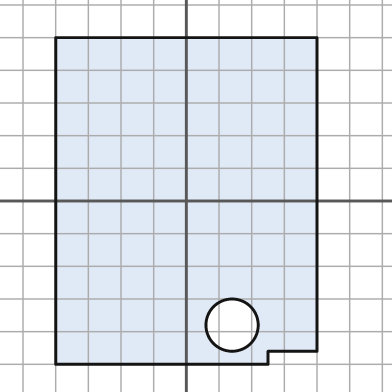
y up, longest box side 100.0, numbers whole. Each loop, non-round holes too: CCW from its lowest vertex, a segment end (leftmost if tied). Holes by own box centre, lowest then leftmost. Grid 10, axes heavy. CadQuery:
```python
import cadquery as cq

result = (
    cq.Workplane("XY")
    .moveTo(-40.0, -50.0)
    .lineTo(25.0, -50.0)
    .lineTo(25.0, -46.0)
    .lineTo(40.0, -46.0)
    .lineTo(40.0, 50.0)
    .lineTo(-40.0, 50.0)
    .close()
    .moveTo(14.0, -38.0)
    .circle(8.0)
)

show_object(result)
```